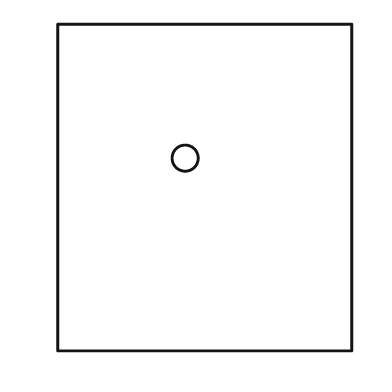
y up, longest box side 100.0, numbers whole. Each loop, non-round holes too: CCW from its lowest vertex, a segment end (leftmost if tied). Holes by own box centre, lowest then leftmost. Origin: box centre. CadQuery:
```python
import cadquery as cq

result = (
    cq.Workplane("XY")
    .moveTo(-45.0, -50.0)
    .lineTo(45.0, -50.0)
    .lineTo(45.0, 50.0)
    .lineTo(-45.0, 50.0)
    .close()
    .moveTo(-6.0, 9.0)
    .circle(4.0)
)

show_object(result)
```